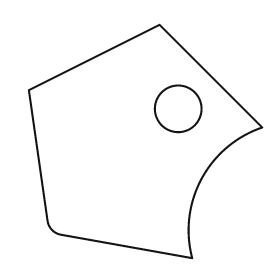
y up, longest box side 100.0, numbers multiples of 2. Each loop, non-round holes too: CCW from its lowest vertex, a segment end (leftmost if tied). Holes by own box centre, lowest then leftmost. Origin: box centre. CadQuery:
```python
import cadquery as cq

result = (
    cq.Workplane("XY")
    .moveTo(20.0, -50.0)
    .threePointArc((24.0, -16.0), (50.0, 6.0))
    .lineTo(6.0, 50.0)
    .lineTo(-50.0, 22.0)
    .lineTo(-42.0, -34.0)
    .threePointArc((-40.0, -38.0), (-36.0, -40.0))
    .close()
    .moveTo(14.0, 14.0)
    .circle(10.0)
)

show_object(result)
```